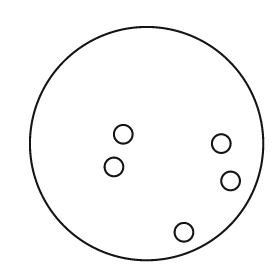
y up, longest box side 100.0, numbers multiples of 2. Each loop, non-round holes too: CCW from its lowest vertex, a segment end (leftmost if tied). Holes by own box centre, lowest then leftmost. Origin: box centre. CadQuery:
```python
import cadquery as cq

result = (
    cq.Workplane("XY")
    .moveTo(0.0, 0.0)
    .circle(50.0)
    .moveTo(16.0, -38.0)
    .circle(4.0)
    .moveTo(36.0, -16.0)
    .circle(4.0)
    .moveTo(-14.0, -10.0)
    .circle(4.0)
    .moveTo(32.0, 0.0)
    .circle(4.0)
    .moveTo(-10.0, 4.0)
    .circle(4.0)
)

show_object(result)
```